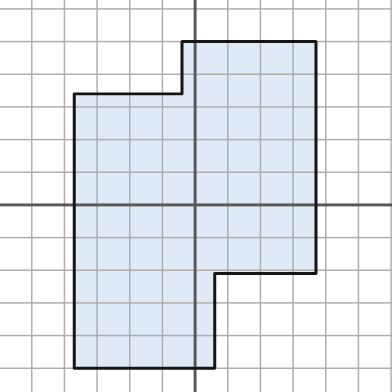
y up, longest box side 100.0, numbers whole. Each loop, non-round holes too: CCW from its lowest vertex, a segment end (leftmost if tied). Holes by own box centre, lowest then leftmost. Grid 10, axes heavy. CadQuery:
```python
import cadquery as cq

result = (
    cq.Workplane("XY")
    .moveTo(-37.0, -50.0)
    .lineTo(6.0, -50.0)
    .lineTo(6.0, -21.0)
    .lineTo(37.0, -21.0)
    .lineTo(37.0, 50.0)
    .lineTo(-4.0, 50.0)
    .lineTo(-4.0, 34.0)
    .lineTo(-37.0, 34.0)
    .close()
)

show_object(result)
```